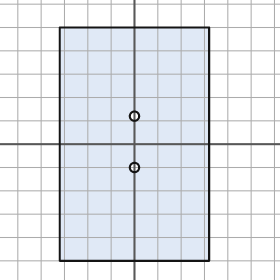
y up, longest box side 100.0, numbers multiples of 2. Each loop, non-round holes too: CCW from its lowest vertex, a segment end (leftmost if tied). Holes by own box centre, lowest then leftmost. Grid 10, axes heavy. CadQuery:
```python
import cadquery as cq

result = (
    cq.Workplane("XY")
    .moveTo(-32.0, -50.0)
    .lineTo(32.0, -50.0)
    .lineTo(32.0, 50.0)
    .lineTo(-32.0, 50.0)
    .close()
    .moveTo(0.0, -10.0)
    .circle(2.0)
    .moveTo(0.0, 12.0)
    .circle(2.0)
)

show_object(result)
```